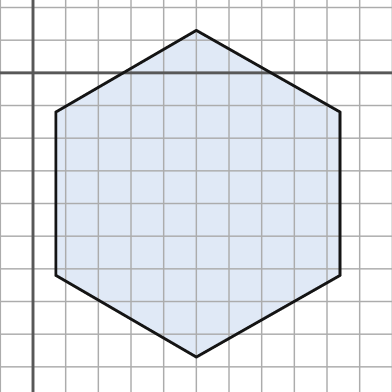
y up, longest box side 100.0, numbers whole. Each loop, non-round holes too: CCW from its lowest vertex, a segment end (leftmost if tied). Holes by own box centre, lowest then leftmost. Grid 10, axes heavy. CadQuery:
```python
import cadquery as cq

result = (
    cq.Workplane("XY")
    .moveTo(50.0, -87.0)
    .lineTo(94.0, -62.0)
    .lineTo(94.0, -12.0)
    .lineTo(50.0, 13.0)
    .lineTo(7.0, -12.0)
    .lineTo(7.0, -62.0)
    .close()
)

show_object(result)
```